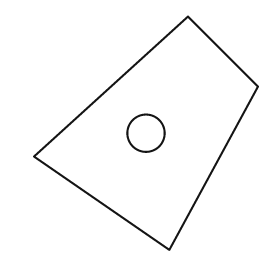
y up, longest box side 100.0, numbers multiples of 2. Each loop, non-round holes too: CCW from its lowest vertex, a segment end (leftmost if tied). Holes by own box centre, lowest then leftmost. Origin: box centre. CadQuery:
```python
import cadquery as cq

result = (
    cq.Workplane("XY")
    .moveTo(10.0, -50.0)
    .lineTo(48.0, 20.0)
    .lineTo(18.0, 50.0)
    .lineTo(-48.0, -10.0)
    .close()
    .moveTo(0.0, 0.0)
    .circle(8.0)
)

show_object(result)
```